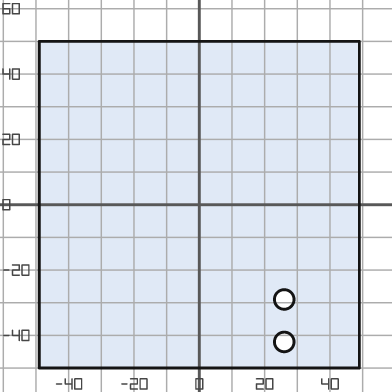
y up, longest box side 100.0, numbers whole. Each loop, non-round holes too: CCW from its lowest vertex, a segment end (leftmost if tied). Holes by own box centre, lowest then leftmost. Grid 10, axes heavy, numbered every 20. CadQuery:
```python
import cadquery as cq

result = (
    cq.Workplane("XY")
    .moveTo(-49.0, -50.0)
    .lineTo(49.0, -50.0)
    .lineTo(49.0, 50.0)
    .lineTo(-49.0, 50.0)
    .close()
    .moveTo(26.0, -42.0)
    .circle(3.0)
    .moveTo(26.0, -29.0)
    .circle(3.0)
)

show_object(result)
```